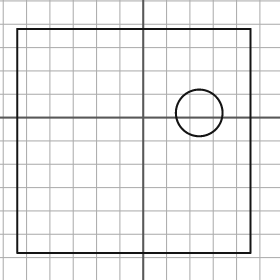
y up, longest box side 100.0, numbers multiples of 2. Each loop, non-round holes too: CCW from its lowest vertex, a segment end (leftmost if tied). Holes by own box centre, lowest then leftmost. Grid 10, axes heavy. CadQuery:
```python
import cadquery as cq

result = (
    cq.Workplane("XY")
    .moveTo(-54.0, -58.0)
    .lineTo(46.0, -58.0)
    .lineTo(46.0, 38.0)
    .lineTo(-54.0, 38.0)
    .close()
    .moveTo(24.0, 2.0)
    .circle(10.0)
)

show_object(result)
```